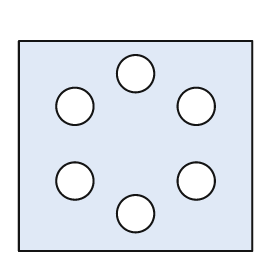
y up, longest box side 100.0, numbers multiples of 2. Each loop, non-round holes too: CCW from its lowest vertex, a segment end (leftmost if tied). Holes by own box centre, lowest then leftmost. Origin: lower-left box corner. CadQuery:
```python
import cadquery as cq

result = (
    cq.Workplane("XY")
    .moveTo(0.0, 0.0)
    .lineTo(100.0, 0.0)
    .lineTo(100.0, 90.0)
    .lineTo(0.0, 90.0)
    .close()
    .moveTo(50.0, 16.0)
    .circle(8.0)
    .moveTo(24.0, 30.0)
    .circle(8.0)
    .moveTo(76.0, 30.0)
    .circle(8.0)
    .moveTo(24.0, 62.0)
    .circle(8.0)
    .moveTo(76.0, 62.0)
    .circle(8.0)
    .moveTo(50.0, 76.0)
    .circle(8.0)
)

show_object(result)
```